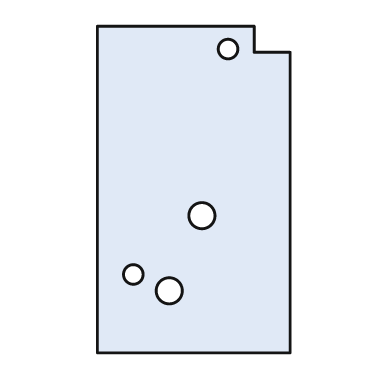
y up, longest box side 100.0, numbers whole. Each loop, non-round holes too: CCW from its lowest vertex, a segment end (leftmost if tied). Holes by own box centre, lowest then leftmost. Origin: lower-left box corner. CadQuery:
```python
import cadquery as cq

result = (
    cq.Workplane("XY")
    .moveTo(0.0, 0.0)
    .lineTo(59.0, 0.0)
    .lineTo(59.0, 92.0)
    .lineTo(48.0, 92.0)
    .lineTo(48.0, 100.0)
    .lineTo(0.0, 100.0)
    .close()
    .moveTo(22.0, 19.0)
    .circle(4.0)
    .moveTo(11.0, 24.0)
    .circle(3.0)
    .moveTo(32.0, 42.0)
    .circle(4.0)
    .moveTo(40.0, 93.0)
    .circle(3.0)
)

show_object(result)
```